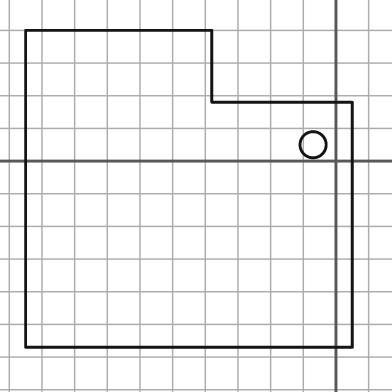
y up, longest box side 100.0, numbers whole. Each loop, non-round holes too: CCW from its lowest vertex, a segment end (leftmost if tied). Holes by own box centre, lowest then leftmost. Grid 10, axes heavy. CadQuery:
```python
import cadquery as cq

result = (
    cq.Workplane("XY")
    .moveTo(-95.0, -57.0)
    .lineTo(5.0, -57.0)
    .lineTo(5.0, 18.0)
    .lineTo(-38.0, 18.0)
    .lineTo(-38.0, 40.0)
    .lineTo(-95.0, 40.0)
    .close()
    .moveTo(-7.0, 5.0)
    .circle(4.0)
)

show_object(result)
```